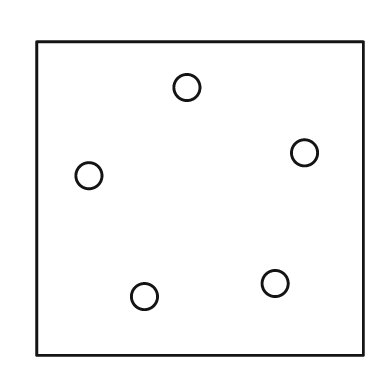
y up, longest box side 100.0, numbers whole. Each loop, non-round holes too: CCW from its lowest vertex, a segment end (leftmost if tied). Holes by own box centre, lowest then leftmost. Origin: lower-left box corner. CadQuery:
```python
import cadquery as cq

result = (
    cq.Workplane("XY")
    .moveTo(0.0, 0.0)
    .lineTo(100.0, 0.0)
    .lineTo(100.0, 96.0)
    .lineTo(0.0, 96.0)
    .close()
    .moveTo(33.0, 18.0)
    .circle(4.0)
    .moveTo(73.0, 22.0)
    .circle(4.0)
    .moveTo(16.0, 55.0)
    .circle(4.0)
    .moveTo(82.0, 62.0)
    .circle(4.0)
    .moveTo(46.0, 82.0)
    .circle(4.0)
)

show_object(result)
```